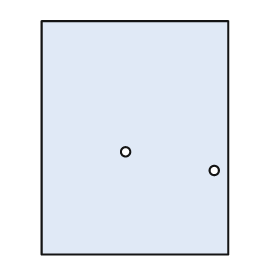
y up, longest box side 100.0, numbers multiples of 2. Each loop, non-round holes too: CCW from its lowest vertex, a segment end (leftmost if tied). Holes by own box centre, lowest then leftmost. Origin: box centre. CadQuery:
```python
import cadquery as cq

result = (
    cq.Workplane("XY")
    .moveTo(-40.0, -50.0)
    .lineTo(40.0, -50.0)
    .lineTo(40.0, 50.0)
    .lineTo(-40.0, 50.0)
    .close()
    .moveTo(34.0, -14.0)
    .circle(2.0)
    .moveTo(-4.0, -6.0)
    .circle(2.0)
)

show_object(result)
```